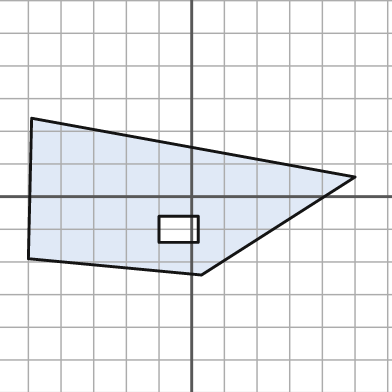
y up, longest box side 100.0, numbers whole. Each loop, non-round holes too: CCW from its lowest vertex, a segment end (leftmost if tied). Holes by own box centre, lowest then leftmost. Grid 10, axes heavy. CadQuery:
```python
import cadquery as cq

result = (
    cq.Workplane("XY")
    .moveTo(3.0, -24.0)
    .lineTo(50.0, 6.0)
    .lineTo(-49.0, 24.0)
    .lineTo(-50.0, -19.0)
    .close()
    .moveTo(-10.0, -14.0)
    .lineTo(2.0, -14.0)
    .lineTo(2.0, -6.0)
    .lineTo(-10.0, -6.0)
    .close()
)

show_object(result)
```